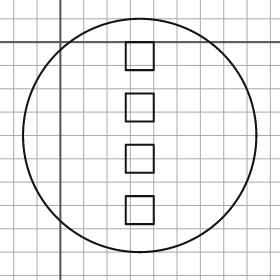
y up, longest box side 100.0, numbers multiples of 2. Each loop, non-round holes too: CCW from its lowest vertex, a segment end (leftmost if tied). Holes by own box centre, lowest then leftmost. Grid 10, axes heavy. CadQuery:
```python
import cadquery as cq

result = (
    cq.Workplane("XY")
    .moveTo(34.0, -40.0)
    .circle(50.0)
    .moveTo(28.0, -78.0)
    .lineTo(40.0, -78.0)
    .lineTo(40.0, -66.0)
    .lineTo(28.0, -66.0)
    .close()
    .moveTo(28.0, -56.0)
    .lineTo(40.0, -56.0)
    .lineTo(40.0, -44.0)
    .lineTo(28.0, -44.0)
    .close()
    .moveTo(28.0, -34.0)
    .lineTo(40.0, -34.0)
    .lineTo(40.0, -22.0)
    .lineTo(28.0, -22.0)
    .close()
    .moveTo(28.0, -12.0)
    .lineTo(40.0, -12.0)
    .lineTo(40.0, 0.0)
    .lineTo(28.0, 0.0)
    .close()
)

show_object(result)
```